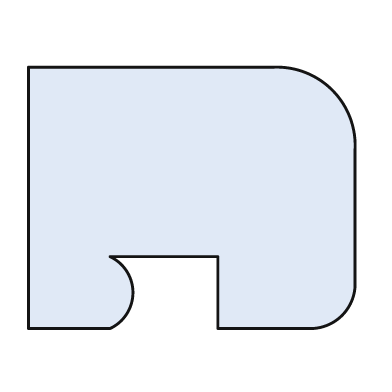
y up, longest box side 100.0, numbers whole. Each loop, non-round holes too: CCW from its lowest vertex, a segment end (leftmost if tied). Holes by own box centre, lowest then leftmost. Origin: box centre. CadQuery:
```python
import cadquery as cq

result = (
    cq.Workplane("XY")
    .moveTo(-50.0, -40.0)
    .lineTo(-25.0, -40.0)
    .threePointArc((-18.0, -29.0), (-25.0, -18.0))
    .lineTo(8.0, -18.0)
    .lineTo(8.0, -40.0)
    .lineTo(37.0, -40.0)
    .threePointArc((46.0, -36.0), (50.0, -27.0))
    .lineTo(50.0, 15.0)
    .threePointArc((43.0, 33.0), (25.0, 40.0))
    .lineTo(-50.0, 40.0)
    .close()
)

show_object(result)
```